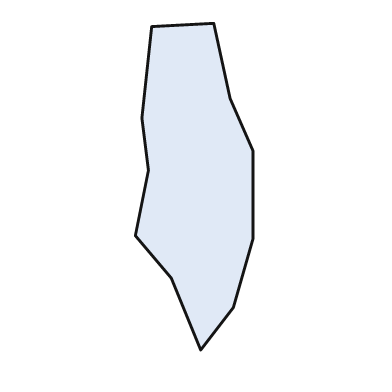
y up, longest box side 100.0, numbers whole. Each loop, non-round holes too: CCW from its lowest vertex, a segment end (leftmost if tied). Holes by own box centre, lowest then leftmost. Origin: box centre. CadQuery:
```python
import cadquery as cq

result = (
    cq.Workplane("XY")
    .moveTo(2.0, -50.0)
    .lineTo(12.0, -37.0)
    .lineTo(18.0, -16.0)
    .lineTo(18.0, 11.0)
    .lineTo(11.0, 27.0)
    .lineTo(6.0, 50.0)
    .lineTo(-13.0, 49.0)
    .lineTo(-16.0, 21.0)
    .lineTo(-14.0, 5.0)
    .lineTo(-18.0, -15.0)
    .lineTo(-7.0, -28.0)
    .close()
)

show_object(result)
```